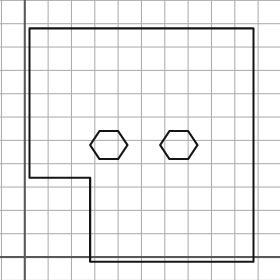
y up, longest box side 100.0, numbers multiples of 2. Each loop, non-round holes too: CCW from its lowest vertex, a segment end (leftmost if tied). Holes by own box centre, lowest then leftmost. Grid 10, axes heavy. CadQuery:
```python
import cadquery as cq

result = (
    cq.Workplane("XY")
    .moveTo(28.0, -2.0)
    .lineTo(98.0, -2.0)
    .lineTo(98.0, 98.0)
    .lineTo(2.0, 98.0)
    .lineTo(2.0, 34.0)
    .lineTo(28.0, 34.0)
    .close()
    .moveTo(32.0, 42.0)
    .lineTo(40.0, 42.0)
    .lineTo(44.0, 48.0)
    .lineTo(40.0, 54.0)
    .lineTo(32.0, 54.0)
    .lineTo(28.0, 48.0)
    .close()
    .moveTo(62.0, 42.0)
    .lineTo(70.0, 42.0)
    .lineTo(74.0, 48.0)
    .lineTo(70.0, 54.0)
    .lineTo(62.0, 54.0)
    .lineTo(58.0, 48.0)
    .close()
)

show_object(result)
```